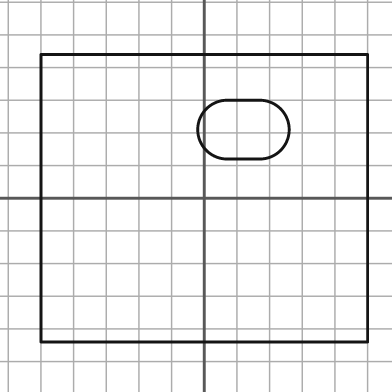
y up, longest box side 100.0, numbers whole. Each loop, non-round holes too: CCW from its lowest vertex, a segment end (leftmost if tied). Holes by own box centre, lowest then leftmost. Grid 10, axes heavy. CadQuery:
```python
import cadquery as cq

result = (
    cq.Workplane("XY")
    .moveTo(-50.0, -44.0)
    .lineTo(50.0, -44.0)
    .lineTo(50.0, 44.0)
    .lineTo(-50.0, 44.0)
    .close()
    .moveTo(7.0, 12.0)
    .lineTo(17.0, 12.0)
    .threePointArc((26.0, 21.0), (17.0, 30.0))
    .lineTo(7.0, 30.0)
    .threePointArc((-2.0, 21.0), (7.0, 12.0))
    .close()
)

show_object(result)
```